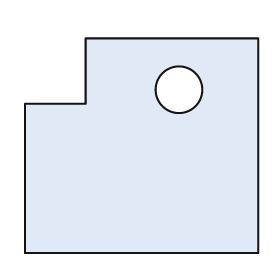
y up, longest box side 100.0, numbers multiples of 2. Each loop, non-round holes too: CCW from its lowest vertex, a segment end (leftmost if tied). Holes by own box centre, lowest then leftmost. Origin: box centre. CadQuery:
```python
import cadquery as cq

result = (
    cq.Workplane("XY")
    .moveTo(-50.0, -46.0)
    .lineTo(50.0, -46.0)
    .lineTo(50.0, 46.0)
    .lineTo(-24.0, 46.0)
    .lineTo(-24.0, 18.0)
    .lineTo(-50.0, 18.0)
    .close()
    .moveTo(16.0, 24.0)
    .circle(10.0)
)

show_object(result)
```